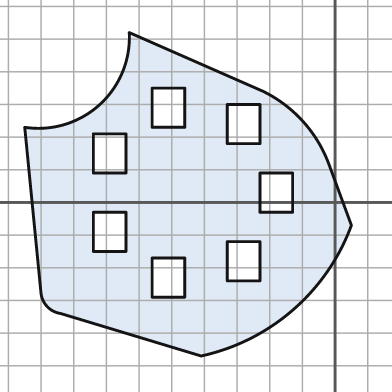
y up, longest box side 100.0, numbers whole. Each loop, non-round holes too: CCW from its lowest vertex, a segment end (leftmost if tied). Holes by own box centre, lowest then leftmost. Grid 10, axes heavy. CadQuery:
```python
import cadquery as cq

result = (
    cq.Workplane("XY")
    .moveTo(-41.0, -47.0)
    .threePointArc((-13.0, -33.0), (5.0, -7.0))
    .lineTo(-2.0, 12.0)
    .threePointArc((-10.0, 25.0), (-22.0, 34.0))
    .lineTo(-63.0, 52.0)
    .threePointArc((-72.0, 30.0), (-95.0, 23.0))
    .lineTo(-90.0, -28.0)
    .threePointArc((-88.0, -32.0), (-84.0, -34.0))
    .close()
    .moveTo(-56.0, -29.0)
    .lineTo(-46.0, -29.0)
    .lineTo(-46.0, -17.0)
    .lineTo(-56.0, -17.0)
    .close()
    .moveTo(-33.0, -24.0)
    .lineTo(-23.0, -24.0)
    .lineTo(-23.0, -12.0)
    .lineTo(-33.0, -12.0)
    .close()
    .moveTo(-74.0, -15.0)
    .lineTo(-64.0, -15.0)
    .lineTo(-64.0, -3.0)
    .lineTo(-74.0, -3.0)
    .close()
    .moveTo(-23.0, -3.0)
    .lineTo(-13.0, -3.0)
    .lineTo(-13.0, 9.0)
    .lineTo(-23.0, 9.0)
    .close()
    .moveTo(-74.0, 9.0)
    .lineTo(-64.0, 9.0)
    .lineTo(-64.0, 21.0)
    .lineTo(-74.0, 21.0)
    .close()
    .moveTo(-33.0, 18.0)
    .lineTo(-23.0, 18.0)
    .lineTo(-23.0, 30.0)
    .lineTo(-33.0, 30.0)
    .close()
    .moveTo(-56.0, 23.0)
    .lineTo(-46.0, 23.0)
    .lineTo(-46.0, 35.0)
    .lineTo(-56.0, 35.0)
    .close()
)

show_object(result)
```